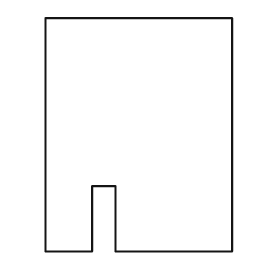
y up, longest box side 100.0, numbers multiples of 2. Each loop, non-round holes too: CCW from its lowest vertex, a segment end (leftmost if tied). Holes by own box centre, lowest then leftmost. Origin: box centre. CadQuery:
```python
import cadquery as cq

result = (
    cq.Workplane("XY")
    .moveTo(-40.0, -50.0)
    .lineTo(-20.0, -50.0)
    .lineTo(-20.0, -22.0)
    .lineTo(-10.0, -22.0)
    .lineTo(-10.0, -50.0)
    .lineTo(40.0, -50.0)
    .lineTo(40.0, 50.0)
    .lineTo(-40.0, 50.0)
    .close()
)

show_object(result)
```